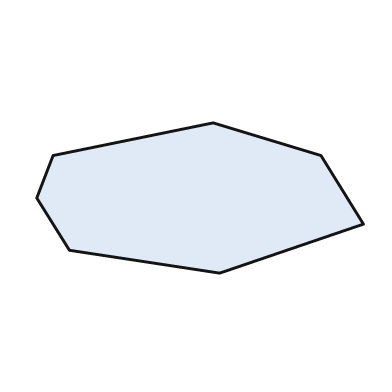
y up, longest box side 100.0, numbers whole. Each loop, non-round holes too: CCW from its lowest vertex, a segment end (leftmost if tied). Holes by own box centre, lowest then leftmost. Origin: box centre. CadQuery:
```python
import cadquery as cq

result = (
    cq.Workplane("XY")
    .moveTo(6.0, -23.0)
    .lineTo(50.0, -8.0)
    .lineTo(37.0, 13.0)
    .lineTo(4.0, 23.0)
    .lineTo(-45.0, 13.0)
    .lineTo(-50.0, 0.0)
    .lineTo(-40.0, -16.0)
    .close()
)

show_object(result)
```